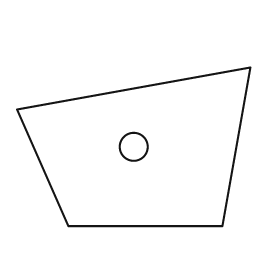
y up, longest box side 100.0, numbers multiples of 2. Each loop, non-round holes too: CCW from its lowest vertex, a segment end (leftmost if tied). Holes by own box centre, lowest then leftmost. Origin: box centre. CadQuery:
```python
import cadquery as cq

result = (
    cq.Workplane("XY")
    .moveTo(-28.0, -34.0)
    .lineTo(38.0, -34.0)
    .lineTo(50.0, 34.0)
    .lineTo(-50.0, 16.0)
    .close()
    .moveTo(0.0, 0.0)
    .circle(6.0)
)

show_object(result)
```